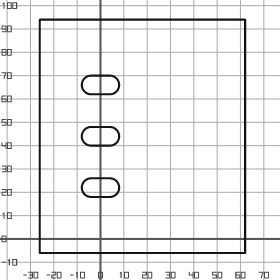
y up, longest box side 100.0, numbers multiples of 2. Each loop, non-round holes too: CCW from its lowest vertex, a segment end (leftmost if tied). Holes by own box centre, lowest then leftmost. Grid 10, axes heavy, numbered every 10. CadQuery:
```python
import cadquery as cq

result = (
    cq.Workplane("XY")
    .moveTo(-26.0, -6.0)
    .lineTo(62.0, -6.0)
    .lineTo(62.0, 94.0)
    .lineTo(-26.0, 94.0)
    .close()
    .moveTo(-4.0, 18.0)
    .lineTo(4.0, 18.0)
    .threePointArc((8.0, 22.0), (4.0, 26.0))
    .lineTo(-4.0, 26.0)
    .threePointArc((-8.0, 22.0), (-4.0, 18.0))
    .close()
    .moveTo(-4.0, 40.0)
    .lineTo(4.0, 40.0)
    .threePointArc((8.0, 44.0), (4.0, 48.0))
    .lineTo(-4.0, 48.0)
    .threePointArc((-8.0, 44.0), (-4.0, 40.0))
    .close()
    .moveTo(-4.0, 62.0)
    .lineTo(4.0, 62.0)
    .threePointArc((8.0, 66.0), (4.0, 70.0))
    .lineTo(-4.0, 70.0)
    .threePointArc((-8.0, 66.0), (-4.0, 62.0))
    .close()
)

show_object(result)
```